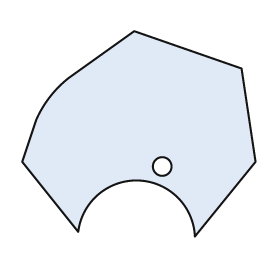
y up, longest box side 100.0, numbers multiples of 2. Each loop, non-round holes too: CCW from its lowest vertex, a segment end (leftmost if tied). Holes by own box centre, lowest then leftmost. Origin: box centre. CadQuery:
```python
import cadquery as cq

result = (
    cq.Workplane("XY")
    .moveTo(24.0, -44.0)
    .lineTo(50.0, -12.0)
    .lineTo(44.0, 28.0)
    .lineTo(-2.0, 44.0)
    .lineTo(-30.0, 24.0)
    .threePointArc((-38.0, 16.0), (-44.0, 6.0))
    .lineTo(-50.0, -12.0)
    .lineTo(-26.0, -42.0)
    .threePointArc((0.0, -20.0), (24.0, -44.0))
    .close()
    .moveTo(10.0, -14.0)
    .circle(4.0)
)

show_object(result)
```